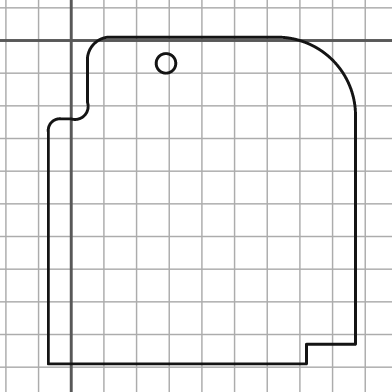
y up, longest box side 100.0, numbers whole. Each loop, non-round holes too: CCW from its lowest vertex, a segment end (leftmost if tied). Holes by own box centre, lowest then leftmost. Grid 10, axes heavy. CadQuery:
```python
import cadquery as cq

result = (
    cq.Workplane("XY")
    .moveTo(-7.0, -99.0)
    .lineTo(72.0, -99.0)
    .lineTo(72.0, -93.0)
    .lineTo(87.0, -93.0)
    .lineTo(87.0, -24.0)
    .threePointArc((80.0, -6.0), (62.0, 1.0))
    .lineTo(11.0, 1.0)
    .threePointArc((7.0, -1.0), (5.0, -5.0))
    .lineTo(5.0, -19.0)
    .threePointArc((4.0, -23.0), (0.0, -24.0))
    .lineTo(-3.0, -24.0)
    .threePointArc((-6.0, -25.0), (-7.0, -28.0))
    .close()
    .moveTo(29.0, -7.0)
    .circle(3.0)
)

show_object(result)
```